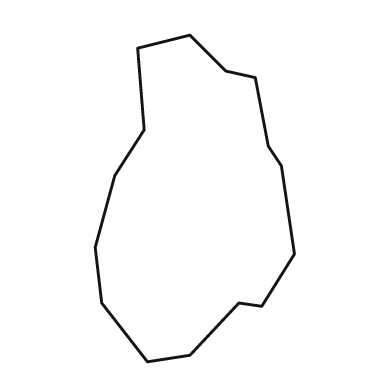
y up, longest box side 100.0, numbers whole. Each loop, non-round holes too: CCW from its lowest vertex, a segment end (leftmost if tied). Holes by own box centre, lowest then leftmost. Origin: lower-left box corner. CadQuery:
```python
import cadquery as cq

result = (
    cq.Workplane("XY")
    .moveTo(16.0, 0.0)
    .lineTo(29.0, 2.0)
    .lineTo(44.0, 18.0)
    .lineTo(51.0, 17.0)
    .lineTo(61.0, 33.0)
    .lineTo(57.0, 60.0)
    .lineTo(53.0, 66.0)
    .lineTo(49.0, 87.0)
    .lineTo(40.0, 89.0)
    .lineTo(29.0, 100.0)
    .lineTo(13.0, 96.0)
    .lineTo(15.0, 71.0)
    .lineTo(6.0, 57.0)
    .lineTo(0.0, 35.0)
    .lineTo(2.0, 18.0)
    .close()
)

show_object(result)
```